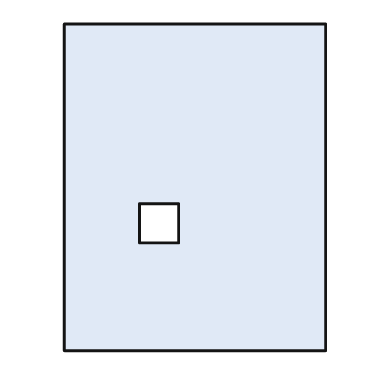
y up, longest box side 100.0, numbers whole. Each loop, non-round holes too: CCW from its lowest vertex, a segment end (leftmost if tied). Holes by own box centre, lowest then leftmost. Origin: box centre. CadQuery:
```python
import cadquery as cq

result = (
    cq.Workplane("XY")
    .moveTo(-40.0, -50.0)
    .lineTo(40.0, -50.0)
    .lineTo(40.0, 50.0)
    .lineTo(-40.0, 50.0)
    .close()
    .moveTo(-17.0, -17.0)
    .lineTo(-5.0, -17.0)
    .lineTo(-5.0, -5.0)
    .lineTo(-17.0, -5.0)
    .close()
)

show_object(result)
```